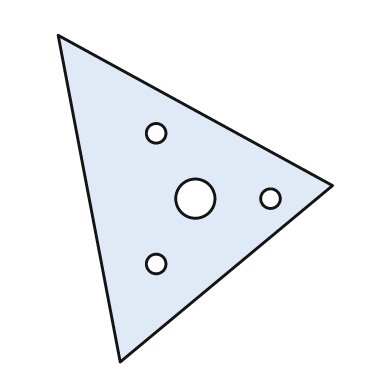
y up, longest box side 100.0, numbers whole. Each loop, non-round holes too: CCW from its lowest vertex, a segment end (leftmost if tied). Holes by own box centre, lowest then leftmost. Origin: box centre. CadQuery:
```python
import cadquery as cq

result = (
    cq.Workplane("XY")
    .moveTo(-23.0, -50.0)
    .lineTo(42.0, 4.0)
    .lineTo(-42.0, 50.0)
    .close()
    .moveTo(-12.0, -20.0)
    .circle(3.0)
    .moveTo(0.0, 0.0)
    .circle(6.0)
    .moveTo(23.0, 0.0)
    .circle(3.0)
    .moveTo(-12.0, 20.0)
    .circle(3.0)
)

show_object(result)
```